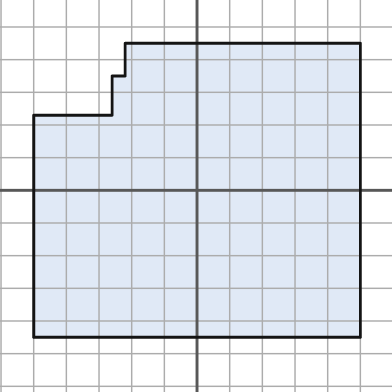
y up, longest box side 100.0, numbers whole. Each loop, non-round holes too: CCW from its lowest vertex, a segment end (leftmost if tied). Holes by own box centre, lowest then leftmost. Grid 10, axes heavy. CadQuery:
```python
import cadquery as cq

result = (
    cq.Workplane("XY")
    .moveTo(-50.0, -45.0)
    .lineTo(50.0, -45.0)
    .lineTo(50.0, 45.0)
    .lineTo(-22.0, 45.0)
    .lineTo(-22.0, 35.0)
    .lineTo(-26.0, 35.0)
    .lineTo(-26.0, 23.0)
    .lineTo(-50.0, 23.0)
    .close()
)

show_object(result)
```